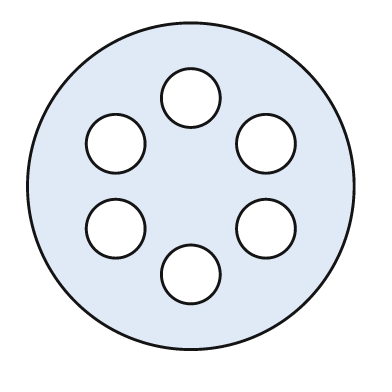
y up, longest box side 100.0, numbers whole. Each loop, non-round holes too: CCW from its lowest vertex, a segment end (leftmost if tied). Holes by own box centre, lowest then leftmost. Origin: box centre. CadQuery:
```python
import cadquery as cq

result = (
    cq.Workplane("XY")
    .moveTo(0.0, 0.0)
    .circle(50.0)
    .moveTo(0.0, -27.0)
    .circle(9.0)
    .moveTo(-23.0, -13.0)
    .circle(9.0)
    .moveTo(23.0, -13.0)
    .circle(9.0)
    .moveTo(-23.0, 13.0)
    .circle(9.0)
    .moveTo(23.0, 13.0)
    .circle(9.0)
    .moveTo(0.0, 27.0)
    .circle(9.0)
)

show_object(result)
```